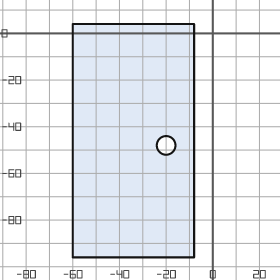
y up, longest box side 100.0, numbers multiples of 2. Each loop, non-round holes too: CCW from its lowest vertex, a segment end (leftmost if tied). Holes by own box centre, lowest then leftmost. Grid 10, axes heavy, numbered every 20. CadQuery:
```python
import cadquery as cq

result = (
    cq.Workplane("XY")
    .moveTo(-60.0, -96.0)
    .lineTo(-8.0, -96.0)
    .lineTo(-8.0, 4.0)
    .lineTo(-60.0, 4.0)
    .close()
    .moveTo(-20.0, -48.0)
    .circle(4.0)
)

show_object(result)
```